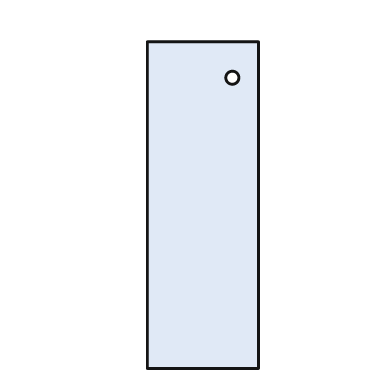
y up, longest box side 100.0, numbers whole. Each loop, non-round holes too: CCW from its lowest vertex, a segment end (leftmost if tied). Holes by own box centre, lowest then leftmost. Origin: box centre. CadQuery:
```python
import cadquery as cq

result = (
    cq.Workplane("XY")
    .moveTo(-17.0, -50.0)
    .lineTo(17.0, -50.0)
    .lineTo(17.0, 50.0)
    .lineTo(-17.0, 50.0)
    .close()
    .moveTo(9.0, 39.0)
    .circle(2.0)
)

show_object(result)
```